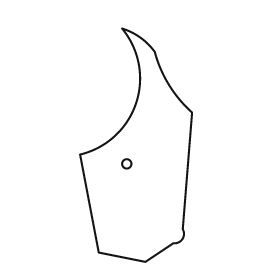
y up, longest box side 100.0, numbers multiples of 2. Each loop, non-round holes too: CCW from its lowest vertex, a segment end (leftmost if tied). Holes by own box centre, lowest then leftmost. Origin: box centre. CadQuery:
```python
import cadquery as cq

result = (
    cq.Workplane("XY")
    .moveTo(4.0, -50.0)
    .lineTo(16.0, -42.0)
    .threePointArc((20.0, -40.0), (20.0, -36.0))
    .lineTo(24.0, 14.0)
    .threePointArc((14.0, 26.0), (8.0, 40.0))
    .threePointArc((2.0, 46.0), (-6.0, 50.0))
    .threePointArc((0.0, 18.0), (-24.0, -4.0))
    .lineTo(-16.0, -46.0)
    .close()
    .moveTo(-4.0, -8.0)
    .circle(2.0)
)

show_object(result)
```